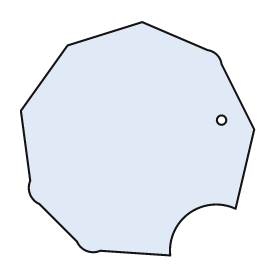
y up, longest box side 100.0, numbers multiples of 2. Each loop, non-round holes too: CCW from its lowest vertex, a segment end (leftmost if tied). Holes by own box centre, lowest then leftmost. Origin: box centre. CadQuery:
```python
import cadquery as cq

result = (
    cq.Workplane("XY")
    .moveTo(14.0, -50.0)
    .threePointArc((22.0, -32.0), (42.0, -30.0))
    .lineTo(50.0, 4.0)
    .lineTo(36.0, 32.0)
    .threePointArc((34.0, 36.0), (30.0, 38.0))
    .lineTo(2.0, 50.0)
    .lineTo(-30.0, 40.0)
    .lineTo(-50.0, 12.0)
    .lineTo(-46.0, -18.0)
    .threePointArc((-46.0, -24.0), (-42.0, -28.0))
    .lineTo(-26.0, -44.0)
    .threePointArc((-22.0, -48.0), (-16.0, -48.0))
    .close()
    .moveTo(36.0, 8.0)
    .circle(2.0)
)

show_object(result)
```